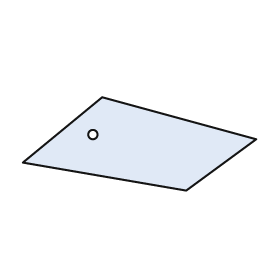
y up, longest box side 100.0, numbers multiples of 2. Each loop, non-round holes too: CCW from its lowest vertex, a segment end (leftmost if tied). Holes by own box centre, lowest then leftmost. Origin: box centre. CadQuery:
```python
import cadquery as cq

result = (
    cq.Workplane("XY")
    .moveTo(20.0, -20.0)
    .lineTo(50.0, 2.0)
    .lineTo(-16.0, 20.0)
    .lineTo(-50.0, -8.0)
    .close()
    .moveTo(-20.0, 4.0)
    .circle(2.0)
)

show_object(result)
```